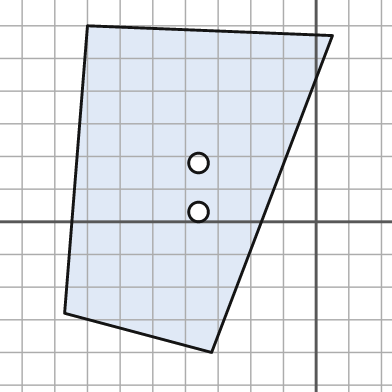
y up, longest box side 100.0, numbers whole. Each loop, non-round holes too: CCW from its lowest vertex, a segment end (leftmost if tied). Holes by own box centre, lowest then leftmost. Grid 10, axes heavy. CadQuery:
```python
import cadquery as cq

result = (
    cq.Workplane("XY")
    .moveTo(-32.0, -40.0)
    .lineTo(5.0, 57.0)
    .lineTo(-70.0, 60.0)
    .lineTo(-77.0, -28.0)
    .close()
    .moveTo(-36.0, 3.0)
    .circle(3.0)
    .moveTo(-36.0, 18.0)
    .circle(3.0)
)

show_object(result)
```